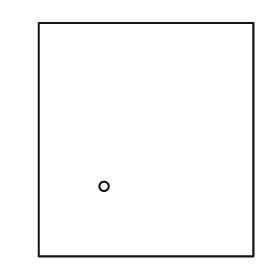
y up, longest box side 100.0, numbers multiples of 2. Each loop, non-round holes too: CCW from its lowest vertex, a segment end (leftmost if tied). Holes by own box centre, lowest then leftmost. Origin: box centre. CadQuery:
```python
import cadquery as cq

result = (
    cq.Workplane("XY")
    .moveTo(-46.0, -50.0)
    .lineTo(46.0, -50.0)
    .lineTo(46.0, 50.0)
    .lineTo(-46.0, 50.0)
    .close()
    .moveTo(-18.0, -20.0)
    .circle(2.0)
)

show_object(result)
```